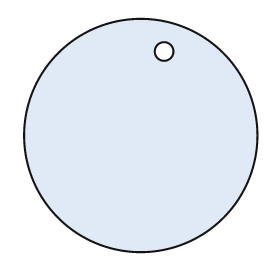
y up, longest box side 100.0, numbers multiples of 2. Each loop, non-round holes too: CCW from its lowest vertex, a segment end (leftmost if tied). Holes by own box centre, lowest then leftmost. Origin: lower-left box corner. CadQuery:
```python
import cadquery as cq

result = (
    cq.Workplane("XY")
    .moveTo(50.0, 50.0)
    .circle(50.0)
    .moveTo(60.0, 86.0)
    .circle(4.0)
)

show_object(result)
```